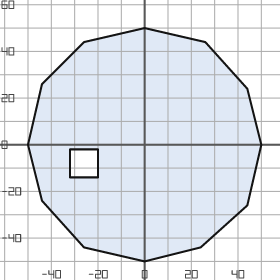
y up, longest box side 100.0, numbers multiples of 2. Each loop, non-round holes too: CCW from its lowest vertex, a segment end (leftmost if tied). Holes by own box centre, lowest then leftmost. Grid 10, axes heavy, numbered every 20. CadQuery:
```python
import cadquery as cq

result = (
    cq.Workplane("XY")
    .moveTo(0.0, -50.0)
    .lineTo(24.0, -44.0)
    .lineTo(44.0, -26.0)
    .lineTo(50.0, 0.0)
    .lineTo(44.0, 24.0)
    .lineTo(26.0, 44.0)
    .lineTo(0.0, 50.0)
    .lineTo(-26.0, 44.0)
    .lineTo(-44.0, 26.0)
    .lineTo(-50.0, 0.0)
    .lineTo(-44.0, -24.0)
    .lineTo(-26.0, -44.0)
    .close()
    .moveTo(-32.0, -14.0)
    .lineTo(-20.0, -14.0)
    .lineTo(-20.0, -2.0)
    .lineTo(-32.0, -2.0)
    .close()
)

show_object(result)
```